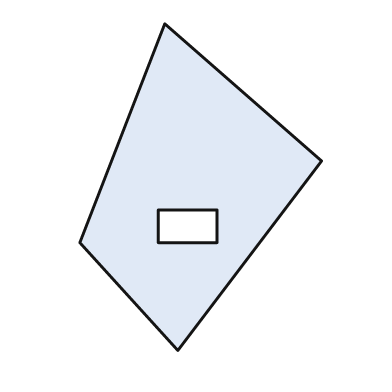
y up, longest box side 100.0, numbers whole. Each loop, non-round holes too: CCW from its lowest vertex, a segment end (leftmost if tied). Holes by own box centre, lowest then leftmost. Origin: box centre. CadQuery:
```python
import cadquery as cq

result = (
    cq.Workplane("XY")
    .moveTo(-7.0, -50.0)
    .lineTo(37.0, 8.0)
    .lineTo(-11.0, 50.0)
    .lineTo(-37.0, -17.0)
    .close()
    .moveTo(-13.0, -17.0)
    .lineTo(5.0, -17.0)
    .lineTo(5.0, -7.0)
    .lineTo(-13.0, -7.0)
    .close()
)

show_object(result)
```